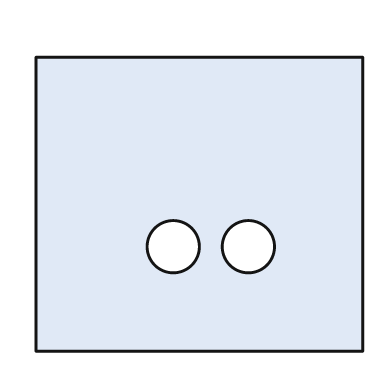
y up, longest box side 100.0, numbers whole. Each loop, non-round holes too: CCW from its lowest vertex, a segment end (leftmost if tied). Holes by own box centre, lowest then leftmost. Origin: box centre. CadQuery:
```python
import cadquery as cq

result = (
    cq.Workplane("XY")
    .moveTo(-50.0, -45.0)
    .lineTo(50.0, -45.0)
    .lineTo(50.0, 45.0)
    .lineTo(-50.0, 45.0)
    .close()
    .moveTo(-8.0, -13.0)
    .circle(8.0)
    .moveTo(15.0, -13.0)
    .circle(8.0)
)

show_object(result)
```